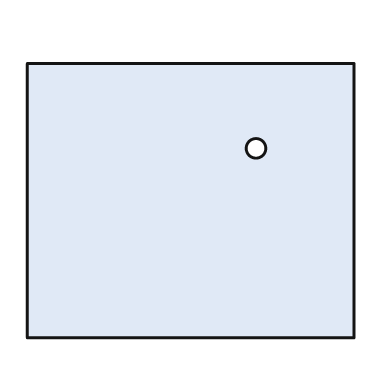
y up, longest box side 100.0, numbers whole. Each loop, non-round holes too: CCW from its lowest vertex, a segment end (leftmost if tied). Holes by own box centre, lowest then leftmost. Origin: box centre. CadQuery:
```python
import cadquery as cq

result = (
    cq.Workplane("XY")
    .moveTo(-50.0, -42.0)
    .lineTo(50.0, -42.0)
    .lineTo(50.0, 42.0)
    .lineTo(-50.0, 42.0)
    .close()
    .moveTo(20.0, 16.0)
    .circle(3.0)
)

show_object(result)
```